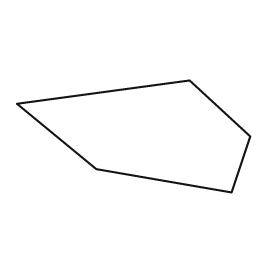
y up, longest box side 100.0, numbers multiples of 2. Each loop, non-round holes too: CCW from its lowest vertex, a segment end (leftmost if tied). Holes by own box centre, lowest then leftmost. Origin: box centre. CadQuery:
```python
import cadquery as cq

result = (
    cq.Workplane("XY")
    .moveTo(42.0, -24.0)
    .lineTo(50.0, 0.0)
    .lineTo(24.0, 24.0)
    .lineTo(-50.0, 14.0)
    .lineTo(-16.0, -14.0)
    .close()
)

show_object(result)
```